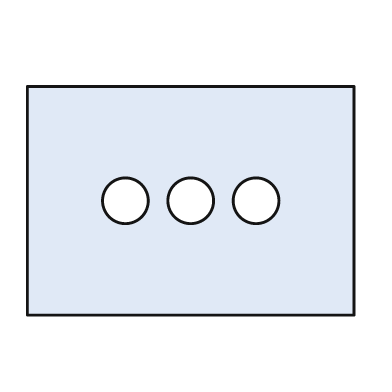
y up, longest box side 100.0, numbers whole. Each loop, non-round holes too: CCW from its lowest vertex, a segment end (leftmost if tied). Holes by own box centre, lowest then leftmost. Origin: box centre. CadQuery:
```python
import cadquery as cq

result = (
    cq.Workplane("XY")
    .moveTo(-50.0, -35.0)
    .lineTo(50.0, -35.0)
    .lineTo(50.0, 35.0)
    .lineTo(-50.0, 35.0)
    .close()
    .moveTo(-20.0, 0.0)
    .circle(7.0)
    .moveTo(0.0, 0.0)
    .circle(7.0)
    .moveTo(20.0, 0.0)
    .circle(7.0)
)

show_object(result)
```